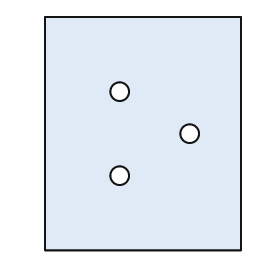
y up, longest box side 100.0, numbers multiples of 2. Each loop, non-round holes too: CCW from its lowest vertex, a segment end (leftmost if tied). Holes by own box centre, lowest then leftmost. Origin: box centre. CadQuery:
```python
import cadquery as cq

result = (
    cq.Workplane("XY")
    .moveTo(-42.0, -50.0)
    .lineTo(42.0, -50.0)
    .lineTo(42.0, 50.0)
    .lineTo(-42.0, 50.0)
    .close()
    .moveTo(-10.0, -18.0)
    .circle(4.0)
    .moveTo(20.0, 0.0)
    .circle(4.0)
    .moveTo(-10.0, 18.0)
    .circle(4.0)
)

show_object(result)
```